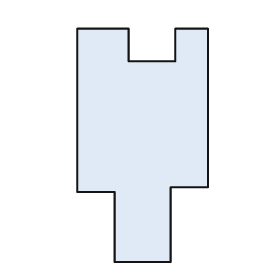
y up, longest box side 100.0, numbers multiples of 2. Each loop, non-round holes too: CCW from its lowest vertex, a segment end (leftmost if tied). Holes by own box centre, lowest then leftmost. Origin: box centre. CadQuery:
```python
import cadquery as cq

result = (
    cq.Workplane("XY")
    .moveTo(-12.0, -50.0)
    .lineTo(12.0, -50.0)
    .lineTo(12.0, -18.0)
    .lineTo(28.0, -18.0)
    .lineTo(28.0, 50.0)
    .lineTo(14.0, 50.0)
    .lineTo(14.0, 36.0)
    .lineTo(-6.0, 36.0)
    .lineTo(-6.0, 50.0)
    .lineTo(-28.0, 50.0)
    .lineTo(-28.0, -20.0)
    .lineTo(-12.0, -20.0)
    .close()
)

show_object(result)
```